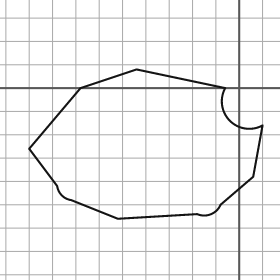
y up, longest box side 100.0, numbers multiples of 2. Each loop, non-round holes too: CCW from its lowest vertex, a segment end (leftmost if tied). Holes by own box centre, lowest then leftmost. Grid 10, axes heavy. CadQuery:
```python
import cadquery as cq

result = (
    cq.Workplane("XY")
    .moveTo(-52.0, -56.0)
    .lineTo(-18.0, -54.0)
    .threePointArc((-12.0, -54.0), (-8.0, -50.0))
    .lineTo(6.0, -38.0)
    .lineTo(10.0, -16.0)
    .threePointArc((-4.0, -14.0), (-6.0, 0.0))
    .lineTo(-44.0, 8.0)
    .lineTo(-68.0, 0.0)
    .lineTo(-90.0, -26.0)
    .lineTo(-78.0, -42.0)
    .threePointArc((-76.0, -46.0), (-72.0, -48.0))
    .close()
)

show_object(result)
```